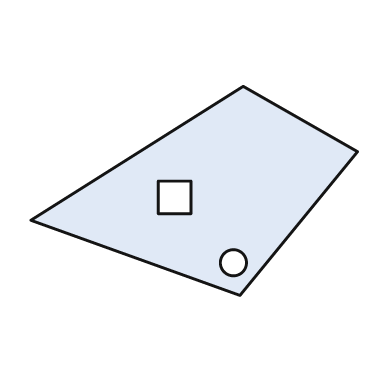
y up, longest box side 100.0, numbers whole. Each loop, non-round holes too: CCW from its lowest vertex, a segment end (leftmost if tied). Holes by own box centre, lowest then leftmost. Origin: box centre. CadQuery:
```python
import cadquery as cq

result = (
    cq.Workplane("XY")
    .moveTo(14.0, -32.0)
    .lineTo(50.0, 12.0)
    .lineTo(15.0, 32.0)
    .lineTo(-50.0, -9.0)
    .close()
    .moveTo(12.0, -22.0)
    .circle(4.0)
    .moveTo(-11.0, -7.0)
    .lineTo(-1.0, -7.0)
    .lineTo(-1.0, 3.0)
    .lineTo(-11.0, 3.0)
    .close()
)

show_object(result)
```